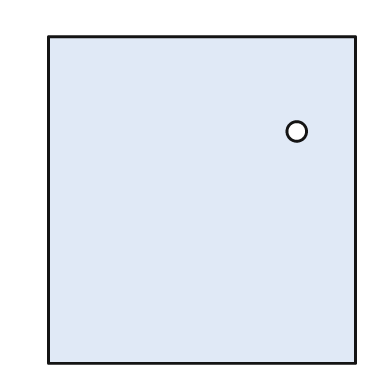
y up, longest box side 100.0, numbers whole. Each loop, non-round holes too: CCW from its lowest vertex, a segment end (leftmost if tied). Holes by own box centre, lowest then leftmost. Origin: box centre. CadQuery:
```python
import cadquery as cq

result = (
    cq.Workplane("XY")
    .moveTo(-47.0, -50.0)
    .lineTo(47.0, -50.0)
    .lineTo(47.0, 50.0)
    .lineTo(-47.0, 50.0)
    .close()
    .moveTo(29.0, 21.0)
    .circle(3.0)
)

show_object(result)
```